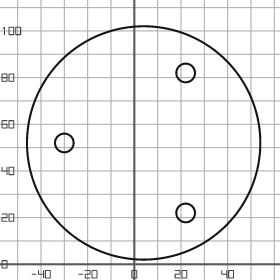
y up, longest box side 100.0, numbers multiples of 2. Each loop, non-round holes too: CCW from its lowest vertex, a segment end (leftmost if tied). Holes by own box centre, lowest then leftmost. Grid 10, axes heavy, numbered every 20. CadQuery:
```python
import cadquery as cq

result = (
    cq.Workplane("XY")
    .moveTo(4.0, 52.0)
    .circle(50.0)
    .moveTo(22.0, 22.0)
    .circle(4.0)
    .moveTo(-30.0, 52.0)
    .circle(4.0)
    .moveTo(22.0, 82.0)
    .circle(4.0)
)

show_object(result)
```